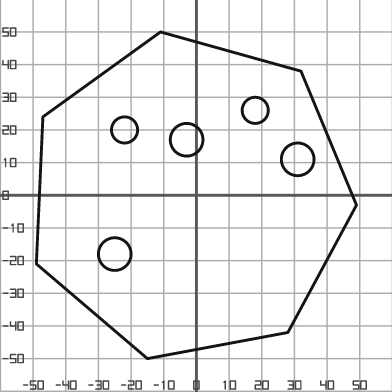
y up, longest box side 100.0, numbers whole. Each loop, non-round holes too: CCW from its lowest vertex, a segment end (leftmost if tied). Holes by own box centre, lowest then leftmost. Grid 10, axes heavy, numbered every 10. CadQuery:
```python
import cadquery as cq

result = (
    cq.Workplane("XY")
    .moveTo(-15.0, -50.0)
    .lineTo(28.0, -42.0)
    .lineTo(49.0, -3.0)
    .lineTo(32.0, 38.0)
    .lineTo(-11.0, 50.0)
    .lineTo(-47.0, 24.0)
    .lineTo(-49.0, -21.0)
    .close()
    .moveTo(-25.0, -18.0)
    .circle(5.0)
    .moveTo(31.0, 11.0)
    .circle(5.0)
    .moveTo(-3.0, 17.0)
    .circle(5.0)
    .moveTo(-22.0, 20.0)
    .circle(4.0)
    .moveTo(18.0, 26.0)
    .circle(4.0)
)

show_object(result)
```